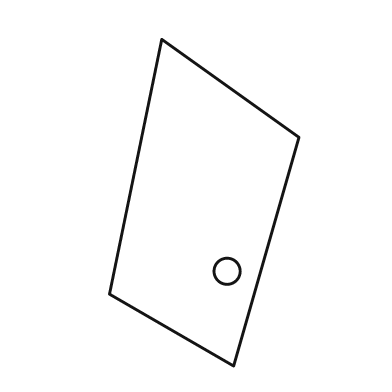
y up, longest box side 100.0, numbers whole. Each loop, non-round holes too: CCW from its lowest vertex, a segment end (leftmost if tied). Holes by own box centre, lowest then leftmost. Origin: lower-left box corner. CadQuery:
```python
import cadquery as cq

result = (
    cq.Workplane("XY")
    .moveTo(38.0, 0.0)
    .lineTo(58.0, 70.0)
    .lineTo(16.0, 100.0)
    .lineTo(0.0, 22.0)
    .close()
    .moveTo(36.0, 29.0)
    .circle(4.0)
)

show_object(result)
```